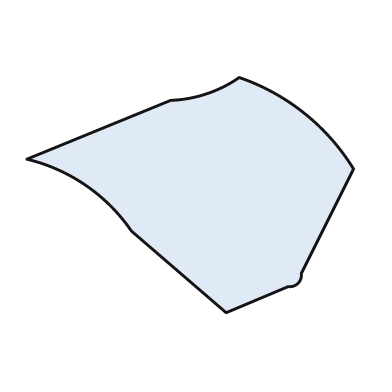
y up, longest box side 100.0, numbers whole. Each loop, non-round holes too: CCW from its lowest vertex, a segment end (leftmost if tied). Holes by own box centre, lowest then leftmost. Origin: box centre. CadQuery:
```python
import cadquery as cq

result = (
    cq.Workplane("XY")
    .moveTo(11.0, -36.0)
    .lineTo(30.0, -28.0)
    .threePointArc((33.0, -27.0), (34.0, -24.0))
    .lineTo(50.0, 8.0)
    .threePointArc((35.0, 25.0), (15.0, 36.0))
    .threePointArc((5.0, 31.0), (-6.0, 29.0))
    .lineTo(-50.0, 11.0)
    .threePointArc((-32.0, 3.0), (-18.0, -11.0))
    .close()
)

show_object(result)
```